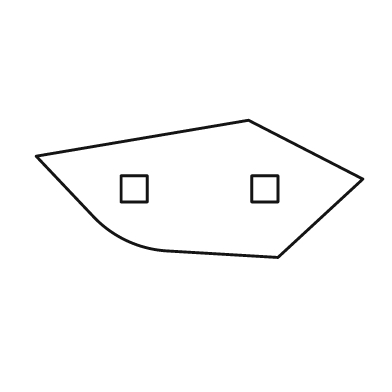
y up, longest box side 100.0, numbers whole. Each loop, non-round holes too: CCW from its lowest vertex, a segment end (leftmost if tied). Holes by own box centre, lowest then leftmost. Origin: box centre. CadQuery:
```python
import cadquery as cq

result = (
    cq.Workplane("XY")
    .moveTo(24.0, -21.0)
    .lineTo(50.0, 3.0)
    .lineTo(15.0, 21.0)
    .lineTo(-50.0, 10.0)
    .lineTo(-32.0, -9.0)
    .threePointArc((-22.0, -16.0), (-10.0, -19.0))
    .close()
    .moveTo(-24.0, -4.0)
    .lineTo(-16.0, -4.0)
    .lineTo(-16.0, 4.0)
    .lineTo(-24.0, 4.0)
    .close()
    .moveTo(16.0, -4.0)
    .lineTo(24.0, -4.0)
    .lineTo(24.0, 4.0)
    .lineTo(16.0, 4.0)
    .close()
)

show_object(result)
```